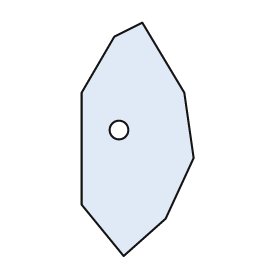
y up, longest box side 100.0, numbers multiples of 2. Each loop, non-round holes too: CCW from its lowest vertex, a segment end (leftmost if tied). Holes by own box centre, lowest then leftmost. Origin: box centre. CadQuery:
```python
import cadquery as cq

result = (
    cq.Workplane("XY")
    .moveTo(-6.0, -50.0)
    .lineTo(12.0, -34.0)
    .lineTo(24.0, -8.0)
    .lineTo(20.0, 20.0)
    .lineTo(2.0, 50.0)
    .lineTo(-10.0, 44.0)
    .lineTo(-24.0, 20.0)
    .lineTo(-24.0, -28.0)
    .close()
    .moveTo(-8.0, 4.0)
    .circle(4.0)
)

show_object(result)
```